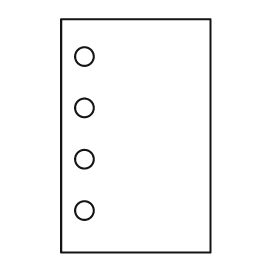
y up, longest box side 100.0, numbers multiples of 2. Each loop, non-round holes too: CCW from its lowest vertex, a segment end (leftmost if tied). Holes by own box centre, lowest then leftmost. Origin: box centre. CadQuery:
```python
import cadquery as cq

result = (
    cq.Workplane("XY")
    .moveTo(-32.0, -50.0)
    .lineTo(32.0, -50.0)
    .lineTo(32.0, 50.0)
    .lineTo(-32.0, 50.0)
    .close()
    .moveTo(-22.0, -32.0)
    .circle(4.0)
    .moveTo(-22.0, -10.0)
    .circle(4.0)
    .moveTo(-22.0, 12.0)
    .circle(4.0)
    .moveTo(-22.0, 34.0)
    .circle(4.0)
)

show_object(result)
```